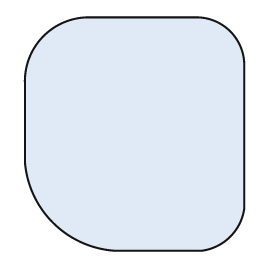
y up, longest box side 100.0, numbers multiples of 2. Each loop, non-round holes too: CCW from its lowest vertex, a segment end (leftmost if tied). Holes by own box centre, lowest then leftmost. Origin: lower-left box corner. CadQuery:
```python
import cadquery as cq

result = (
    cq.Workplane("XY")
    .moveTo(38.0, 0.0)
    .lineTo(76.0, 0.0)
    .threePointArc((88.0, 6.0), (94.0, 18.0))
    .lineTo(94.0, 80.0)
    .threePointArc((88.0, 94.0), (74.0, 100.0))
    .lineTo(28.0, 100.0)
    .threePointArc((8.0, 92.0), (0.0, 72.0))
    .lineTo(0.0, 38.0)
    .threePointArc((12.0, 12.0), (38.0, 0.0))
    .close()
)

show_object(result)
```